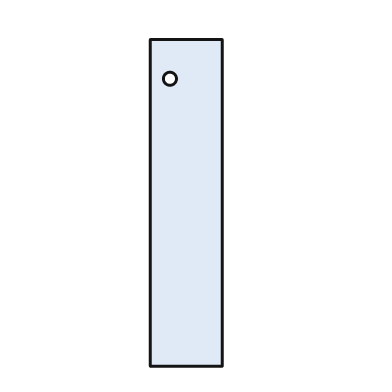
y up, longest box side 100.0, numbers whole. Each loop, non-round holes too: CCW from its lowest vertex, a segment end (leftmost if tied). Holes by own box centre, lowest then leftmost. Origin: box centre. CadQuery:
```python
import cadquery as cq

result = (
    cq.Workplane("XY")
    .moveTo(-11.0, -50.0)
    .lineTo(11.0, -50.0)
    .lineTo(11.0, 50.0)
    .lineTo(-11.0, 50.0)
    .close()
    .moveTo(-5.0, 38.0)
    .circle(2.0)
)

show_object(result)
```